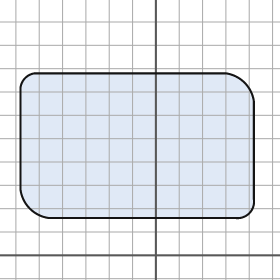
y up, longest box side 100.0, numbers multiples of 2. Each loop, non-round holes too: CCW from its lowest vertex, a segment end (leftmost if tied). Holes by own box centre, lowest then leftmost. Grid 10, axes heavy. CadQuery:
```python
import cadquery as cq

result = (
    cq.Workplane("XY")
    .moveTo(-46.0, 16.0)
    .lineTo(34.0, 16.0)
    .threePointArc((40.0, 18.0), (42.0, 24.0))
    .lineTo(42.0, 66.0)
    .threePointArc((38.0, 74.0), (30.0, 78.0))
    .lineTo(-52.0, 78.0)
    .threePointArc((-56.0, 76.0), (-58.0, 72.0))
    .lineTo(-58.0, 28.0)
    .threePointArc((-54.0, 20.0), (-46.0, 16.0))
    .close()
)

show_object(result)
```